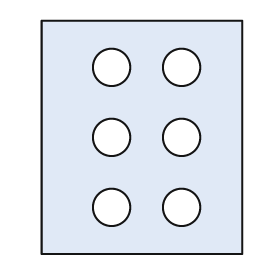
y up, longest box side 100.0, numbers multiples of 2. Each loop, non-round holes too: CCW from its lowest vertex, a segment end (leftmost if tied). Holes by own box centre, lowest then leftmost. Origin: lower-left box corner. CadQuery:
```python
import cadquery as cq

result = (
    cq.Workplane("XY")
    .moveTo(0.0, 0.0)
    .lineTo(86.0, 0.0)
    .lineTo(86.0, 100.0)
    .lineTo(0.0, 100.0)
    .close()
    .moveTo(30.0, 20.0)
    .circle(8.0)
    .moveTo(60.0, 20.0)
    .circle(8.0)
    .moveTo(30.0, 50.0)
    .circle(8.0)
    .moveTo(60.0, 50.0)
    .circle(8.0)
    .moveTo(30.0, 80.0)
    .circle(8.0)
    .moveTo(60.0, 80.0)
    .circle(8.0)
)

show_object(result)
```